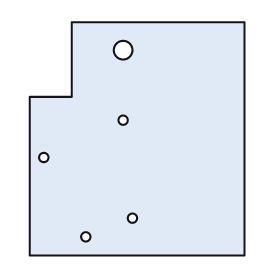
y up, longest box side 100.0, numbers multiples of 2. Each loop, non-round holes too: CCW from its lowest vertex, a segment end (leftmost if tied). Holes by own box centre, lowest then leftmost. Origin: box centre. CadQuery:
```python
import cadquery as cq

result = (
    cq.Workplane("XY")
    .moveTo(-46.0, -50.0)
    .lineTo(46.0, -50.0)
    .lineTo(46.0, 50.0)
    .lineTo(-28.0, 50.0)
    .lineTo(-28.0, 18.0)
    .lineTo(-46.0, 18.0)
    .close()
    .moveTo(-22.0, -42.0)
    .circle(2.0)
    .moveTo(-2.0, -34.0)
    .circle(2.0)
    .moveTo(-40.0, -8.0)
    .circle(2.0)
    .moveTo(-6.0, 8.0)
    .circle(2.0)
    .moveTo(-6.0, 38.0)
    .circle(4.0)
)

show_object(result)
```